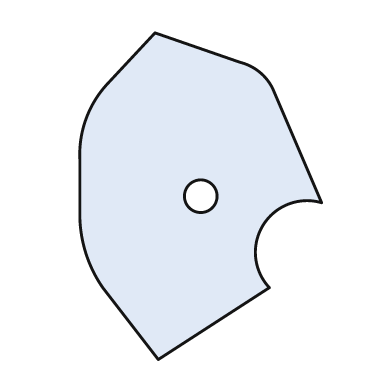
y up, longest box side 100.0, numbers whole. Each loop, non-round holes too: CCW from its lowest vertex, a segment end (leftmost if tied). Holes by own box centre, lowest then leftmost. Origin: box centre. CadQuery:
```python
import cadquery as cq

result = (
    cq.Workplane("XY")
    .moveTo(-13.0, -50.0)
    .lineTo(21.0, -28.0)
    .threePointArc((19.0, -9.0), (37.0, -2.0))
    .lineTo(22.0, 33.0)
    .threePointArc((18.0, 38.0), (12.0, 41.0))
    .lineTo(-14.0, 50.0)
    .lineTo(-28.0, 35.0)
    .threePointArc((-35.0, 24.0), (-37.0, 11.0))
    .lineTo(-37.0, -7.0)
    .threePointArc((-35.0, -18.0), (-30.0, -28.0))
    .close()
    .moveTo(0.0, 0.0)
    .circle(5.0)
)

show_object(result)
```